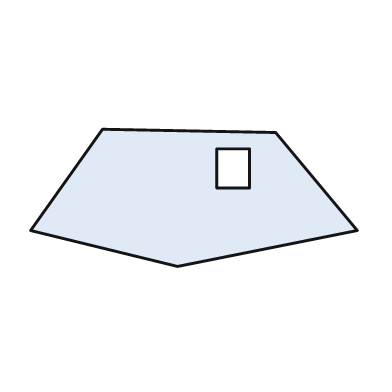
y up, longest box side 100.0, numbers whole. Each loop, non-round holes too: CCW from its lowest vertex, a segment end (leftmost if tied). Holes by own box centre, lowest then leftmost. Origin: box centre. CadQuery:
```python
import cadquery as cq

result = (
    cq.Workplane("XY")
    .moveTo(-5.0, -21.0)
    .lineTo(50.0, -10.0)
    .lineTo(25.0, 20.0)
    .lineTo(-28.0, 21.0)
    .lineTo(-50.0, -10.0)
    .close()
    .moveTo(7.0, 3.0)
    .lineTo(17.0, 3.0)
    .lineTo(17.0, 15.0)
    .lineTo(7.0, 15.0)
    .close()
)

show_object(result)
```